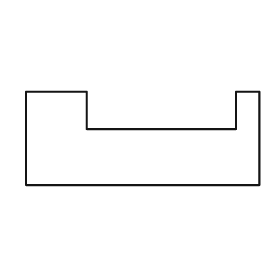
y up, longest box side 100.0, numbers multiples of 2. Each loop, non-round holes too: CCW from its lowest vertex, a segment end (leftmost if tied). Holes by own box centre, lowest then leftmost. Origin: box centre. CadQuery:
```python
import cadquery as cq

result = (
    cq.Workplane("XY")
    .moveTo(-50.0, -20.0)
    .lineTo(50.0, -20.0)
    .lineTo(50.0, 20.0)
    .lineTo(40.0, 20.0)
    .lineTo(40.0, 4.0)
    .lineTo(-24.0, 4.0)
    .lineTo(-24.0, 20.0)
    .lineTo(-50.0, 20.0)
    .close()
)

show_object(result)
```